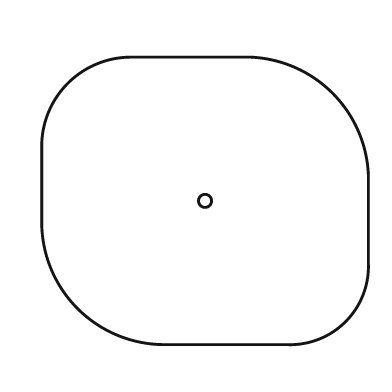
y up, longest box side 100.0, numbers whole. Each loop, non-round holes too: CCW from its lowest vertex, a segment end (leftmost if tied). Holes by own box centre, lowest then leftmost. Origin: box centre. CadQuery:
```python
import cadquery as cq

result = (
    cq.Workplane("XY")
    .moveTo(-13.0, -44.0)
    .lineTo(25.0, -44.0)
    .threePointArc((43.0, -37.0), (50.0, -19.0))
    .lineTo(50.0, 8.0)
    .threePointArc((39.0, 33.0), (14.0, 44.0))
    .lineTo(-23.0, 44.0)
    .threePointArc((-42.0, 36.0), (-50.0, 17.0))
    .lineTo(-50.0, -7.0)
    .threePointArc((-39.0, -33.0), (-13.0, -44.0))
    .close()
    .moveTo(0.0, 0.0)
    .circle(2.0)
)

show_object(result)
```